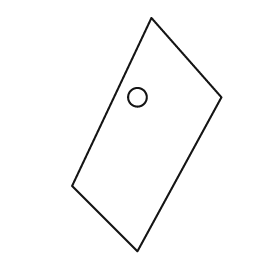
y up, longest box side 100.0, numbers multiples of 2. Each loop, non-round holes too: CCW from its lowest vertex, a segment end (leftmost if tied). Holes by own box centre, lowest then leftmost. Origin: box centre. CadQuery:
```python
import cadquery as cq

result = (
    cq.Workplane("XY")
    .moveTo(-4.0, -50.0)
    .lineTo(32.0, 16.0)
    .lineTo(2.0, 50.0)
    .lineTo(-32.0, -22.0)
    .close()
    .moveTo(-4.0, 16.0)
    .circle(4.0)
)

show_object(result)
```